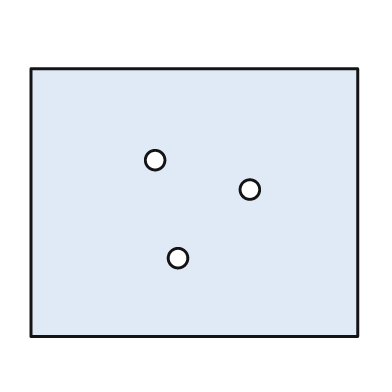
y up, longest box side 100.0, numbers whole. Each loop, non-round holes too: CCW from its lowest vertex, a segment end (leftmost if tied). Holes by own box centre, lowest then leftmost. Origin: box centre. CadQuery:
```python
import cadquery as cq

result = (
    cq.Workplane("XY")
    .moveTo(-50.0, -41.0)
    .lineTo(50.0, -41.0)
    .lineTo(50.0, 41.0)
    .lineTo(-50.0, 41.0)
    .close()
    .moveTo(-5.0, -17.0)
    .circle(3.0)
    .moveTo(17.0, 4.0)
    .circle(3.0)
    .moveTo(-12.0, 13.0)
    .circle(3.0)
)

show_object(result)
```